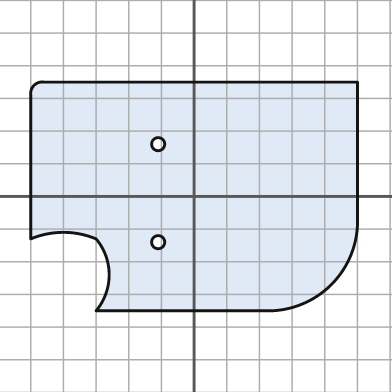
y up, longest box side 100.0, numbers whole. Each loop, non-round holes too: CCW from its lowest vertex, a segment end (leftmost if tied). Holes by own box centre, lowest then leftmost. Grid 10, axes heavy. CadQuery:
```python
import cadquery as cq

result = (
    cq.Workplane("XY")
    .moveTo(-30.0, -35.0)
    .lineTo(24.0, -35.0)
    .threePointArc((42.0, -27.0), (50.0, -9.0))
    .lineTo(50.0, 35.0)
    .lineTo(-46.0, 35.0)
    .threePointArc((-49.0, 34.0), (-50.0, 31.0))
    .lineTo(-50.0, -13.0)
    .threePointArc((-40.0, -11.0), (-30.0, -13.0))
    .threePointArc((-26.0, -24.0), (-30.0, -35.0))
    .close()
    .moveTo(-11.0, -14.0)
    .circle(2.0)
    .moveTo(-11.0, 16.0)
    .circle(2.0)
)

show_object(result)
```